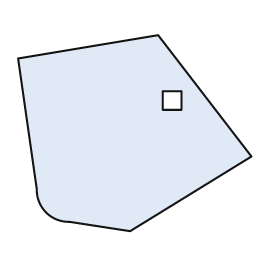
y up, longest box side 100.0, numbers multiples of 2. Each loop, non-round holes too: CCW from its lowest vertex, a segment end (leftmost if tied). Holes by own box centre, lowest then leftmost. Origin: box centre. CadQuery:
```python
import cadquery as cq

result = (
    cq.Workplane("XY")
    .moveTo(-2.0, -42.0)
    .lineTo(50.0, -10.0)
    .lineTo(10.0, 42.0)
    .lineTo(-50.0, 32.0)
    .lineTo(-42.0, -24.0)
    .threePointArc((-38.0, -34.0), (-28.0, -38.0))
    .close()
    .moveTo(12.0, 10.0)
    .lineTo(20.0, 10.0)
    .lineTo(20.0, 18.0)
    .lineTo(12.0, 18.0)
    .close()
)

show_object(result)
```